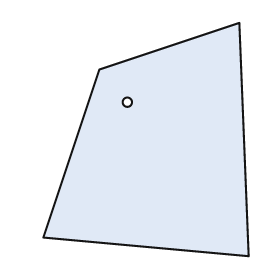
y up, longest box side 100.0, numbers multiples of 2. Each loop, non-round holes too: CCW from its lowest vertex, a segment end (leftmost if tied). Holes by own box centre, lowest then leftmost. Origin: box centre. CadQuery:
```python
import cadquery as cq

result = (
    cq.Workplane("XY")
    .moveTo(44.0, -50.0)
    .lineTo(40.0, 50.0)
    .lineTo(-20.0, 30.0)
    .lineTo(-44.0, -42.0)
    .close()
    .moveTo(-8.0, 16.0)
    .circle(2.0)
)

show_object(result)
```